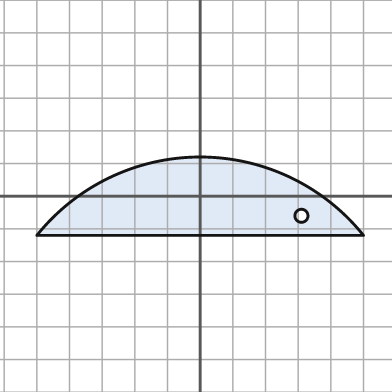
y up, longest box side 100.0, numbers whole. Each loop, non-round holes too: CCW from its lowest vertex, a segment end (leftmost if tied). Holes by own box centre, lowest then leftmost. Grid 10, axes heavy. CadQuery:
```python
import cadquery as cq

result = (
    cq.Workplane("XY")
    .moveTo(-50.0, -12.0)
    .lineTo(50.0, -12.0)
    .threePointArc((0.0, 12.0), (-50.0, -12.0))
    .close()
    .moveTo(31.0, -6.0)
    .circle(2.0)
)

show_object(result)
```